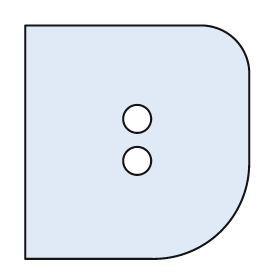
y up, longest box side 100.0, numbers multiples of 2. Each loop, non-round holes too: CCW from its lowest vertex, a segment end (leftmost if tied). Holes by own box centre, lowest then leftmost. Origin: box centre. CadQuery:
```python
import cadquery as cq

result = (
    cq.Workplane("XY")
    .moveTo(-48.0, -50.0)
    .lineTo(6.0, -50.0)
    .threePointArc((36.0, -38.0), (48.0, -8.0))
    .lineTo(48.0, 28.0)
    .threePointArc((42.0, 44.0), (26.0, 50.0))
    .lineTo(-48.0, 50.0)
    .close()
    .moveTo(0.0, -8.0)
    .circle(6.0)
    .moveTo(0.0, 10.0)
    .circle(6.0)
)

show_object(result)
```